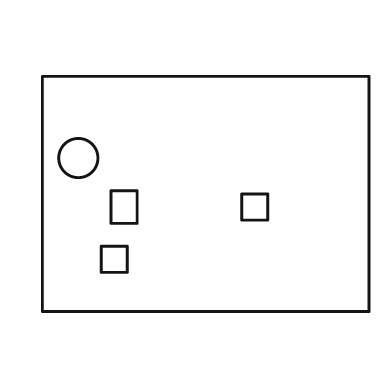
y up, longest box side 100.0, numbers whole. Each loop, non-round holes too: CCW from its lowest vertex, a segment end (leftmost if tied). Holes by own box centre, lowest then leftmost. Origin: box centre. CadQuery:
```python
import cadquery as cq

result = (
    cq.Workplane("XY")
    .moveTo(-50.0, -36.0)
    .lineTo(50.0, -36.0)
    .lineTo(50.0, 36.0)
    .lineTo(-50.0, 36.0)
    .close()
    .moveTo(-32.0, -24.0)
    .lineTo(-24.0, -24.0)
    .lineTo(-24.0, -16.0)
    .lineTo(-32.0, -16.0)
    .close()
    .moveTo(-29.0, -9.0)
    .lineTo(-21.0, -9.0)
    .lineTo(-21.0, 1.0)
    .lineTo(-29.0, 1.0)
    .close()
    .moveTo(11.0, -8.0)
    .lineTo(19.0, -8.0)
    .lineTo(19.0, 0.0)
    .lineTo(11.0, 0.0)
    .close()
    .moveTo(-39.0, 11.0)
    .circle(6.0)
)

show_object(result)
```